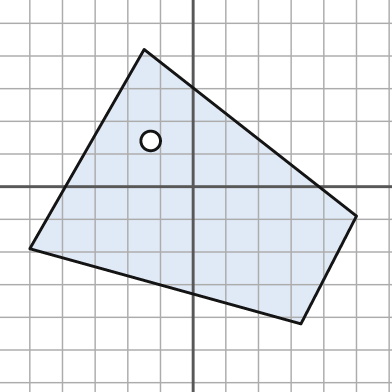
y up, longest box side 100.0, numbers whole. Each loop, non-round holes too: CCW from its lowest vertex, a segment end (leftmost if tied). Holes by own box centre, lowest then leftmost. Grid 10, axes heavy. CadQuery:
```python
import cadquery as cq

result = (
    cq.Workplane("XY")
    .moveTo(33.0, -42.0)
    .lineTo(50.0, -9.0)
    .lineTo(-15.0, 42.0)
    .lineTo(-50.0, -19.0)
    .close()
    .moveTo(-13.0, 14.0)
    .circle(3.0)
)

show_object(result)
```